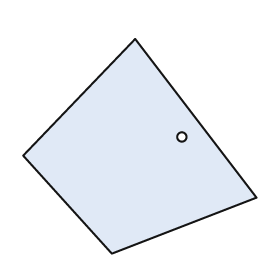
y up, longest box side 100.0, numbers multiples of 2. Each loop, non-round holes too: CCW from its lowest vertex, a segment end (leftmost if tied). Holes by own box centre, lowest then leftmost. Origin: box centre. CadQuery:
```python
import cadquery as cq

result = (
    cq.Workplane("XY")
    .moveTo(-12.0, -46.0)
    .lineTo(50.0, -22.0)
    .lineTo(-2.0, 46.0)
    .lineTo(-50.0, -4.0)
    .close()
    .moveTo(18.0, 4.0)
    .circle(2.0)
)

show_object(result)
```